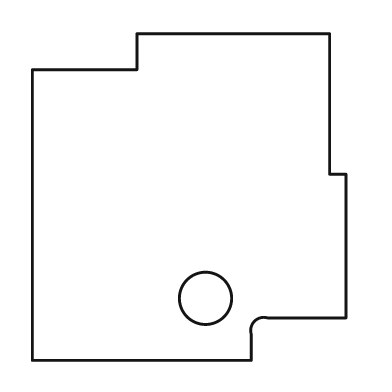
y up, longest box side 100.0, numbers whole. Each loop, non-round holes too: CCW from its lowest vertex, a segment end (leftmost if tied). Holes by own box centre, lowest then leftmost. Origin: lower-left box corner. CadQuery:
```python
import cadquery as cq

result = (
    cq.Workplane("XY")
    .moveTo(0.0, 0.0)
    .lineTo(67.0, 0.0)
    .lineTo(67.0, 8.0)
    .threePointArc((68.0, 12.0), (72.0, 13.0))
    .lineTo(96.0, 13.0)
    .lineTo(96.0, 57.0)
    .lineTo(91.0, 57.0)
    .lineTo(91.0, 100.0)
    .lineTo(32.0, 100.0)
    .lineTo(32.0, 89.0)
    .lineTo(0.0, 89.0)
    .close()
    .moveTo(53.0, 19.0)
    .circle(8.0)
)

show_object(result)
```